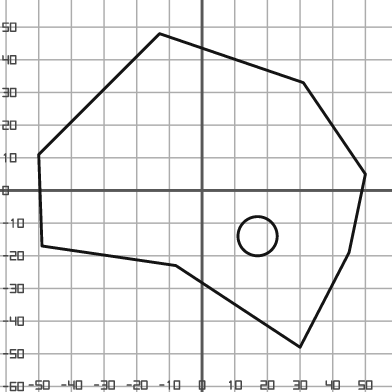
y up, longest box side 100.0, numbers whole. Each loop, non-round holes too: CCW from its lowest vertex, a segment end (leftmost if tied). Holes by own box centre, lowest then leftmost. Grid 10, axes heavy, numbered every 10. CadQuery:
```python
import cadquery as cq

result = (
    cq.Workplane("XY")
    .moveTo(30.0, -48.0)
    .lineTo(45.0, -19.0)
    .lineTo(50.0, 5.0)
    .lineTo(31.0, 33.0)
    .lineTo(-13.0, 48.0)
    .lineTo(-50.0, 11.0)
    .lineTo(-49.0, -17.0)
    .lineTo(-8.0, -23.0)
    .close()
    .moveTo(17.0, -14.0)
    .circle(6.0)
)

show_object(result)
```